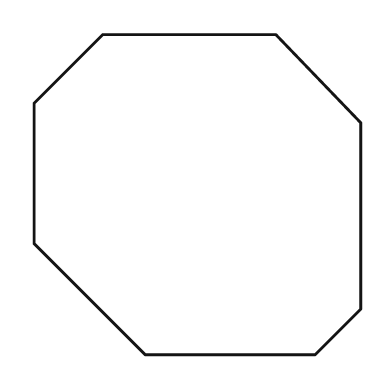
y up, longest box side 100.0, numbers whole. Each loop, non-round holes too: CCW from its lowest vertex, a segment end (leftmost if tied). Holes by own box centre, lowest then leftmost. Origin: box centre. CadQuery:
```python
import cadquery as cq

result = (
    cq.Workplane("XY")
    .moveTo(-16.0, -49.0)
    .lineTo(36.0, -49.0)
    .lineTo(50.0, -35.0)
    .lineTo(50.0, 22.0)
    .lineTo(24.0, 49.0)
    .lineTo(-29.0, 49.0)
    .lineTo(-50.0, 28.0)
    .lineTo(-50.0, -15.0)
    .close()
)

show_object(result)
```